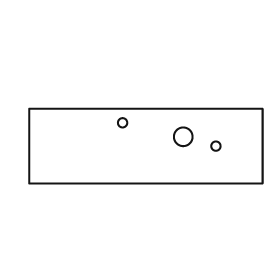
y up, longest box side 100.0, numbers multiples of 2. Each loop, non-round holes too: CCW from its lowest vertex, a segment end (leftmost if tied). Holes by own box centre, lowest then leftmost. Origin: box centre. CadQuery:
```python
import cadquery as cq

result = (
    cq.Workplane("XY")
    .moveTo(-50.0, -16.0)
    .lineTo(50.0, -16.0)
    .lineTo(50.0, 16.0)
    .lineTo(-50.0, 16.0)
    .close()
    .moveTo(30.0, 0.0)
    .circle(2.0)
    .moveTo(16.0, 4.0)
    .circle(4.0)
    .moveTo(-10.0, 10.0)
    .circle(2.0)
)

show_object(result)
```